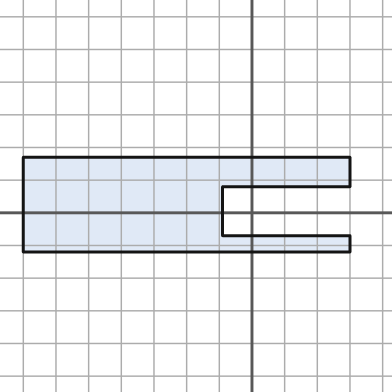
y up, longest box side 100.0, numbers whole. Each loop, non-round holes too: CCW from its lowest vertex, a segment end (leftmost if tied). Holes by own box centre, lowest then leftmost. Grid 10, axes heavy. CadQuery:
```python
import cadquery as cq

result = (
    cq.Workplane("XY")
    .moveTo(-70.0, -12.0)
    .lineTo(30.0, -12.0)
    .lineTo(30.0, -7.0)
    .lineTo(-9.0, -7.0)
    .lineTo(-9.0, 8.0)
    .lineTo(30.0, 8.0)
    .lineTo(30.0, 17.0)
    .lineTo(-70.0, 17.0)
    .close()
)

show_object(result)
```